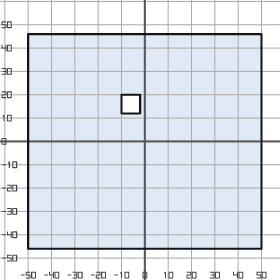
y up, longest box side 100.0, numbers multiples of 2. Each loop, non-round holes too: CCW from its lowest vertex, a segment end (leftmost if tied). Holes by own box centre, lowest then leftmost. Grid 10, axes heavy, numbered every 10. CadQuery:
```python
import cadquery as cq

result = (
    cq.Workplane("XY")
    .moveTo(-50.0, -46.0)
    .lineTo(50.0, -46.0)
    .lineTo(50.0, 46.0)
    .lineTo(-50.0, 46.0)
    .close()
    .moveTo(-10.0, 12.0)
    .lineTo(-2.0, 12.0)
    .lineTo(-2.0, 20.0)
    .lineTo(-10.0, 20.0)
    .close()
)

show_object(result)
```